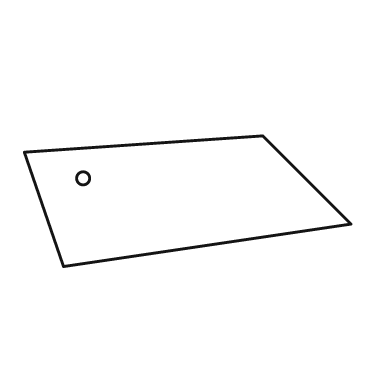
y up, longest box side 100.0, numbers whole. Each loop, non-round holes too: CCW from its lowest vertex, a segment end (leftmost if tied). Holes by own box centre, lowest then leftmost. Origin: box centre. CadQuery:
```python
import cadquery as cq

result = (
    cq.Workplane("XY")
    .moveTo(-38.0, -20.0)
    .lineTo(50.0, -7.0)
    .lineTo(23.0, 20.0)
    .lineTo(-50.0, 15.0)
    .close()
    .moveTo(-32.0, 7.0)
    .circle(2.0)
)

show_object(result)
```